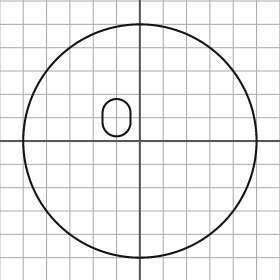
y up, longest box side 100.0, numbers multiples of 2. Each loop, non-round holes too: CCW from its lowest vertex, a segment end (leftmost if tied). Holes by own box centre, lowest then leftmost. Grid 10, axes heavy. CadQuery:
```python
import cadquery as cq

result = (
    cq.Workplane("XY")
    .moveTo(0.0, 0.0)
    .circle(50.0)
    .moveTo(-16.0, 8.0)
    .threePointArc((-10.0, 2.0), (-4.0, 8.0))
    .lineTo(-4.0, 12.0)
    .threePointArc((-10.0, 18.0), (-16.0, 12.0))
    .close()
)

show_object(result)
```